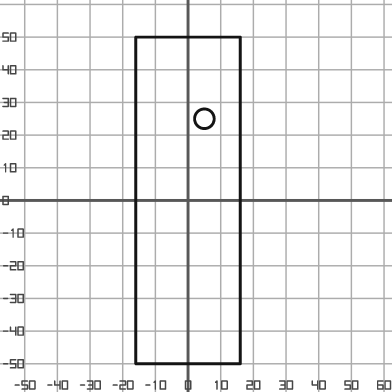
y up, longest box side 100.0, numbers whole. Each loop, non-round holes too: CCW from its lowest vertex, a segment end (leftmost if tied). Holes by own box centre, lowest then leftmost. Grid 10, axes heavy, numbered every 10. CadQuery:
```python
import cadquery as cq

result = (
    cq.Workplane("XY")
    .moveTo(-16.0, -50.0)
    .lineTo(16.0, -50.0)
    .lineTo(16.0, 50.0)
    .lineTo(-16.0, 50.0)
    .close()
    .moveTo(5.0, 25.0)
    .circle(3.0)
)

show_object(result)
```